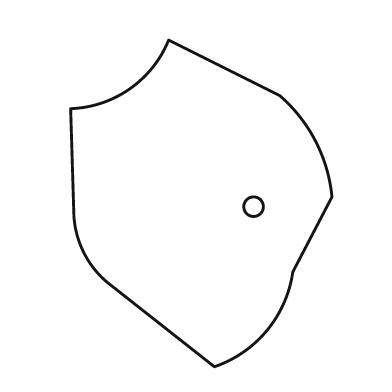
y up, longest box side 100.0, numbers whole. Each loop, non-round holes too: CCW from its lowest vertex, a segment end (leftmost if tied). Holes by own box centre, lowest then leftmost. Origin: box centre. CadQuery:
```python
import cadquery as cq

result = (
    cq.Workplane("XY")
    .moveTo(4.0, -50.0)
    .threePointArc((20.0, -39.0), (28.0, -21.0))
    .lineTo(40.0, 2.0)
    .threePointArc((35.0, 19.0), (24.0, 33.0))
    .lineTo(-10.0, 50.0)
    .threePointArc((-22.0, 35.0), (-40.0, 29.0))
    .lineTo(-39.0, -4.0)
    .threePointArc((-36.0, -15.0), (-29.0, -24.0))
    .close()
    .moveTo(16.0, -1.0)
    .circle(3.0)
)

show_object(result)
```